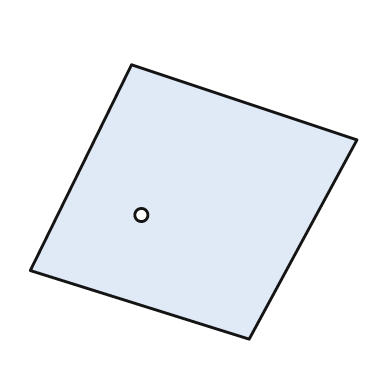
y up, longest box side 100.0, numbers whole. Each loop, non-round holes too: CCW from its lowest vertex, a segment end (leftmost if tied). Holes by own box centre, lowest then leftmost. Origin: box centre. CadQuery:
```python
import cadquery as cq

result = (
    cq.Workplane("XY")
    .moveTo(17.0, -42.0)
    .lineTo(50.0, 19.0)
    .lineTo(-19.0, 42.0)
    .lineTo(-50.0, -21.0)
    .close()
    .moveTo(-16.0, -4.0)
    .circle(2.0)
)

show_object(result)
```